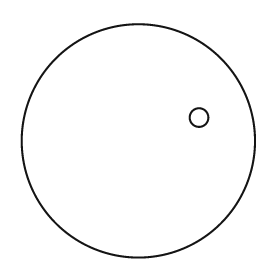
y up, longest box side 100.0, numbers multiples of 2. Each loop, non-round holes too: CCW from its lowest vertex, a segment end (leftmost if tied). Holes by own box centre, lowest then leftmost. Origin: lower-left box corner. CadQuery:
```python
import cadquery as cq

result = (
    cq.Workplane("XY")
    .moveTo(50.0, 50.0)
    .circle(50.0)
    .moveTo(76.0, 60.0)
    .circle(4.0)
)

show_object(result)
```